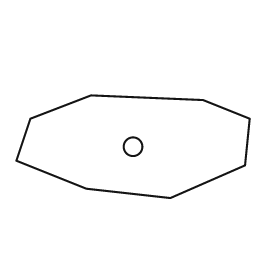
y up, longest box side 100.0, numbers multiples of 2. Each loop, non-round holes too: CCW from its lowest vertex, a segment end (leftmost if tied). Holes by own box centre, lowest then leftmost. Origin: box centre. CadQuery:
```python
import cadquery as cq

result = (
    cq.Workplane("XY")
    .moveTo(16.0, -22.0)
    .lineTo(48.0, -8.0)
    .lineTo(50.0, 12.0)
    .lineTo(30.0, 20.0)
    .lineTo(-18.0, 22.0)
    .lineTo(-44.0, 12.0)
    .lineTo(-50.0, -6.0)
    .lineTo(-20.0, -18.0)
    .close()
    .moveTo(0.0, 0.0)
    .circle(4.0)
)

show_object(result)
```